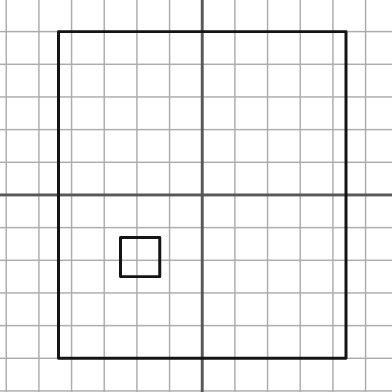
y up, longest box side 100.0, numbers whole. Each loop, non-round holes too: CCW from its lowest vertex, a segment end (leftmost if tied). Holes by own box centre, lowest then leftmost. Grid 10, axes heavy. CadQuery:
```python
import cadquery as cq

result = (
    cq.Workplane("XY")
    .moveTo(-44.0, -50.0)
    .lineTo(44.0, -50.0)
    .lineTo(44.0, 50.0)
    .lineTo(-44.0, 50.0)
    .close()
    .moveTo(-25.0, -25.0)
    .lineTo(-13.0, -25.0)
    .lineTo(-13.0, -13.0)
    .lineTo(-25.0, -13.0)
    .close()
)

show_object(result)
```